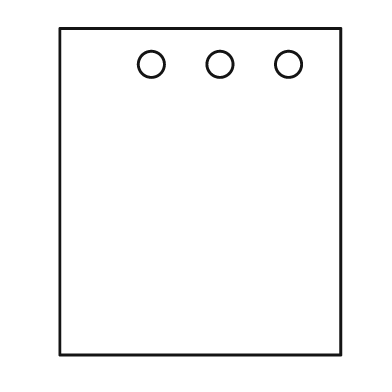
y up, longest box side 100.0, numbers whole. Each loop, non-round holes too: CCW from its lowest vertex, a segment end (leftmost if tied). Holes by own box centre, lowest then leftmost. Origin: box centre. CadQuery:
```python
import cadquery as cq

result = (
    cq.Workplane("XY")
    .moveTo(-43.0, -50.0)
    .lineTo(43.0, -50.0)
    .lineTo(43.0, 50.0)
    .lineTo(-43.0, 50.0)
    .close()
    .moveTo(-15.0, 39.0)
    .circle(4.0)
    .moveTo(6.0, 39.0)
    .circle(4.0)
    .moveTo(27.0, 39.0)
    .circle(4.0)
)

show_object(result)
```